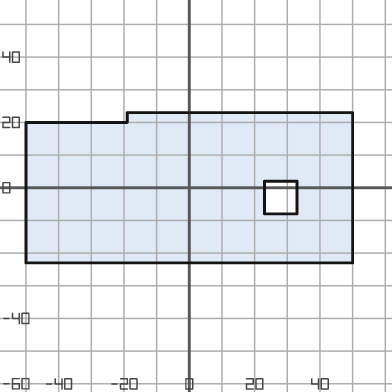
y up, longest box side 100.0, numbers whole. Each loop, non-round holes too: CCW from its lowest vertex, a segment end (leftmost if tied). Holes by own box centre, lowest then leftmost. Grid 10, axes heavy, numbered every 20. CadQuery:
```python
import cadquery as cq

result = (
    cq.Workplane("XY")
    .moveTo(-50.0, -23.0)
    .lineTo(50.0, -23.0)
    .lineTo(50.0, 23.0)
    .lineTo(-19.0, 23.0)
    .lineTo(-19.0, 20.0)
    .lineTo(-50.0, 20.0)
    .close()
    .moveTo(23.0, -8.0)
    .lineTo(33.0, -8.0)
    .lineTo(33.0, 2.0)
    .lineTo(23.0, 2.0)
    .close()
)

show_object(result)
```